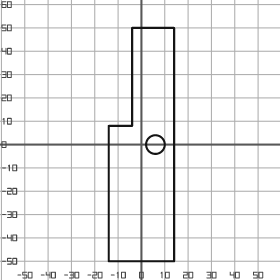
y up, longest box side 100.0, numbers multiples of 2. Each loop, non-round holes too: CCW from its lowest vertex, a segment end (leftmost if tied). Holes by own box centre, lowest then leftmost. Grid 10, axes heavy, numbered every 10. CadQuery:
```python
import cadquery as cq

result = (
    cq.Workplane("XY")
    .moveTo(-14.0, -50.0)
    .lineTo(14.0, -50.0)
    .lineTo(14.0, 50.0)
    .lineTo(-4.0, 50.0)
    .lineTo(-4.0, 8.0)
    .lineTo(-14.0, 8.0)
    .close()
    .moveTo(6.0, 0.0)
    .circle(4.0)
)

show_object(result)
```